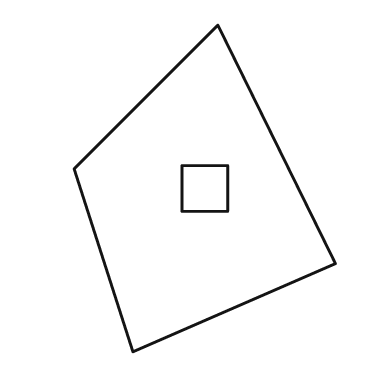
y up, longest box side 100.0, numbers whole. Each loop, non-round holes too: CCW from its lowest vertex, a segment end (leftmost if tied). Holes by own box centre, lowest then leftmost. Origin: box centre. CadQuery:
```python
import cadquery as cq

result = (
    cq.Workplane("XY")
    .moveTo(-22.0, -50.0)
    .lineTo(40.0, -23.0)
    .lineTo(4.0, 50.0)
    .lineTo(-40.0, 6.0)
    .close()
    .moveTo(-7.0, -7.0)
    .lineTo(7.0, -7.0)
    .lineTo(7.0, 7.0)
    .lineTo(-7.0, 7.0)
    .close()
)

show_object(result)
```